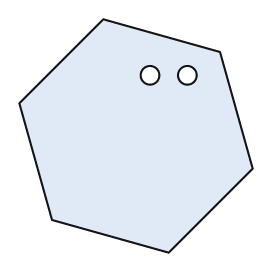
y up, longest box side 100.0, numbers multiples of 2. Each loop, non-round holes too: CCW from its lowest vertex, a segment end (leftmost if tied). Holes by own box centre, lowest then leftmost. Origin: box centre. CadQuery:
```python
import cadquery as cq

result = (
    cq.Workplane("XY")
    .moveTo(14.0, -50.0)
    .lineTo(50.0, -14.0)
    .lineTo(36.0, 36.0)
    .lineTo(-14.0, 50.0)
    .lineTo(-50.0, 14.0)
    .lineTo(-36.0, -36.0)
    .close()
    .moveTo(6.0, 26.0)
    .circle(4.0)
    .moveTo(22.0, 26.0)
    .circle(4.0)
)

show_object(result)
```